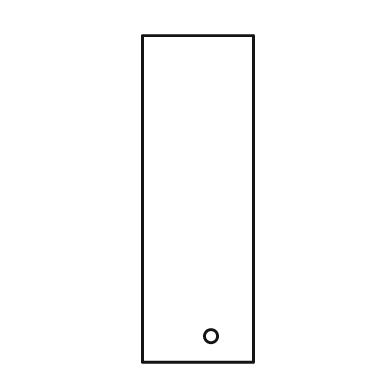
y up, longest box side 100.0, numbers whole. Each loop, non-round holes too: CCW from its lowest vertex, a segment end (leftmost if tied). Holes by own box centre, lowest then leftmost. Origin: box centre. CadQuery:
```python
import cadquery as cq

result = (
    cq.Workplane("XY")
    .moveTo(-17.0, -50.0)
    .lineTo(17.0, -50.0)
    .lineTo(17.0, 50.0)
    .lineTo(-17.0, 50.0)
    .close()
    .moveTo(4.0, -42.0)
    .circle(2.0)
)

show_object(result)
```